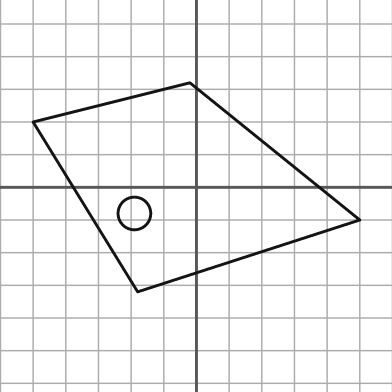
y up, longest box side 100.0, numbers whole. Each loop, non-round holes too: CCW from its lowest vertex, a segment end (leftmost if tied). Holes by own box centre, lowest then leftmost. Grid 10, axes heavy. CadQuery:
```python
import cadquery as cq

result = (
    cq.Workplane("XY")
    .moveTo(-18.0, -32.0)
    .lineTo(50.0, -10.0)
    .lineTo(-2.0, 32.0)
    .lineTo(-50.0, 20.0)
    .close()
    .moveTo(-19.0, -8.0)
    .circle(5.0)
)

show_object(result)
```